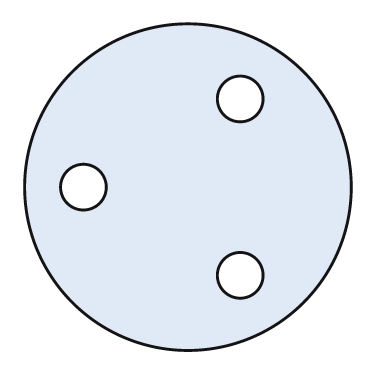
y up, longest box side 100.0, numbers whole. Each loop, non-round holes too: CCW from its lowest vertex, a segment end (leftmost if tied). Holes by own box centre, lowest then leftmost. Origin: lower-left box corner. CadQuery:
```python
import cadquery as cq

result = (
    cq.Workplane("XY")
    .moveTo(50.0, 50.0)
    .circle(50.0)
    .moveTo(66.0, 23.0)
    .circle(7.0)
    .moveTo(18.0, 50.0)
    .circle(7.0)
    .moveTo(66.0, 77.0)
    .circle(7.0)
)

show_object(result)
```